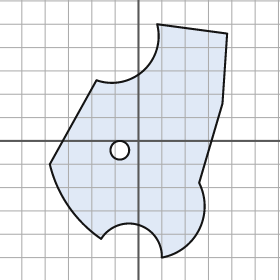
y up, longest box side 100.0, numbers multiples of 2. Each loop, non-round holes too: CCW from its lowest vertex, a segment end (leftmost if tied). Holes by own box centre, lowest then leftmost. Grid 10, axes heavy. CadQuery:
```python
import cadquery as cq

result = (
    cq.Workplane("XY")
    .moveTo(10.0, -50.0)
    .threePointArc((26.0, -38.0), (26.0, -18.0))
    .lineTo(36.0, 16.0)
    .lineTo(38.0, 46.0)
    .lineTo(8.0, 50.0)
    .threePointArc((2.0, 30.0), (-18.0, 26.0))
    .lineTo(-38.0, -10.0)
    .threePointArc((-30.0, -28.0), (-16.0, -42.0))
    .threePointArc((0.0, -36.0), (10.0, -50.0))
    .close()
    .moveTo(-8.0, -4.0)
    .circle(4.0)
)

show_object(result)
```